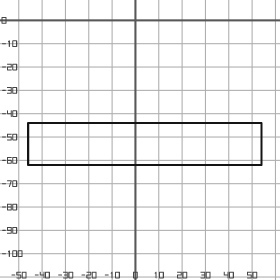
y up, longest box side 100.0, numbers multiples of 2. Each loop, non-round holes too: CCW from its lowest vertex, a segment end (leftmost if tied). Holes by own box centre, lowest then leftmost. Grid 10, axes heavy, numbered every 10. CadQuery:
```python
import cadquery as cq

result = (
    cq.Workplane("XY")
    .moveTo(-46.0, -62.0)
    .lineTo(54.0, -62.0)
    .lineTo(54.0, -44.0)
    .lineTo(-46.0, -44.0)
    .close()
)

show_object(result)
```